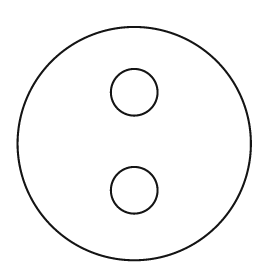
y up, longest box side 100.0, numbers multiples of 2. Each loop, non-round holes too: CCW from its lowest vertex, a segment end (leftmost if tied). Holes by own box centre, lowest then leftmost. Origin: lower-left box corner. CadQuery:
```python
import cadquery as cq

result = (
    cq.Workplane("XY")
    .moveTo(50.0, 50.0)
    .circle(50.0)
    .moveTo(50.0, 30.0)
    .circle(10.0)
    .moveTo(50.0, 72.0)
    .circle(10.0)
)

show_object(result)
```